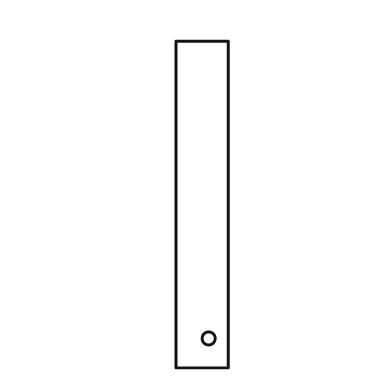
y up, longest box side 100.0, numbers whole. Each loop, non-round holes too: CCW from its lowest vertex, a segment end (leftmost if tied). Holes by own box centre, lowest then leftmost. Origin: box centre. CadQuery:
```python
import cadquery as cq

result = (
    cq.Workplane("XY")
    .moveTo(-8.0, -50.0)
    .lineTo(8.0, -50.0)
    .lineTo(8.0, 50.0)
    .lineTo(-8.0, 50.0)
    .close()
    .moveTo(2.0, -41.0)
    .circle(2.0)
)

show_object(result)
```